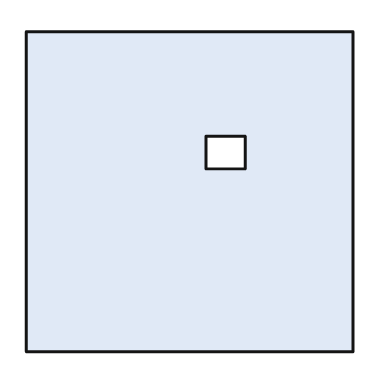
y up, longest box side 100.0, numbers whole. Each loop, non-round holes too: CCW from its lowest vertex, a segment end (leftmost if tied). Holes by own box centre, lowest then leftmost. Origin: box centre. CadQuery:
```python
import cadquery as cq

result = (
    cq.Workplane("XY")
    .moveTo(-50.0, -49.0)
    .lineTo(50.0, -49.0)
    .lineTo(50.0, 49.0)
    .lineTo(-50.0, 49.0)
    .close()
    .moveTo(5.0, 7.0)
    .lineTo(17.0, 7.0)
    .lineTo(17.0, 17.0)
    .lineTo(5.0, 17.0)
    .close()
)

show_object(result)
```